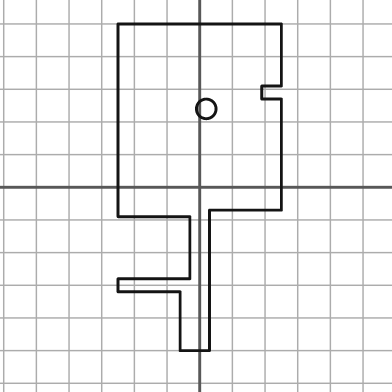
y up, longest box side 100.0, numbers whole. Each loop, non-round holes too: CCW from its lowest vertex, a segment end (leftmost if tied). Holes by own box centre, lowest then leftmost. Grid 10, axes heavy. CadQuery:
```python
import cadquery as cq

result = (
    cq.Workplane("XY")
    .moveTo(-6.0, -50.0)
    .lineTo(3.0, -50.0)
    .lineTo(3.0, -7.0)
    .lineTo(25.0, -7.0)
    .lineTo(25.0, 27.0)
    .lineTo(19.0, 27.0)
    .lineTo(19.0, 31.0)
    .lineTo(25.0, 31.0)
    .lineTo(25.0, 50.0)
    .lineTo(-25.0, 50.0)
    .lineTo(-25.0, -9.0)
    .lineTo(-3.0, -9.0)
    .lineTo(-3.0, -28.0)
    .lineTo(-25.0, -28.0)
    .lineTo(-25.0, -32.0)
    .lineTo(-6.0, -32.0)
    .close()
    .moveTo(2.0, 24.0)
    .circle(3.0)
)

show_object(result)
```